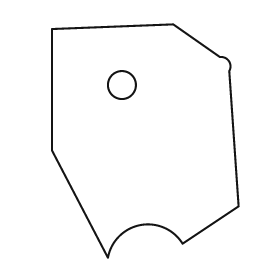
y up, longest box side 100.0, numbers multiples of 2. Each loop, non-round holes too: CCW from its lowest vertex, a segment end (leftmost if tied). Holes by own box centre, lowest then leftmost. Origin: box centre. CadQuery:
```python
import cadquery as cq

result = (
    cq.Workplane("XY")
    .moveTo(-16.0, -50.0)
    .threePointArc((-2.0, -36.0), (16.0, -44.0))
    .lineTo(40.0, -28.0)
    .lineTo(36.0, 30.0)
    .threePointArc((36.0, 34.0), (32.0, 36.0))
    .lineTo(12.0, 50.0)
    .lineTo(-40.0, 48.0)
    .lineTo(-40.0, -4.0)
    .close()
    .moveTo(-10.0, 24.0)
    .circle(6.0)
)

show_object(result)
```